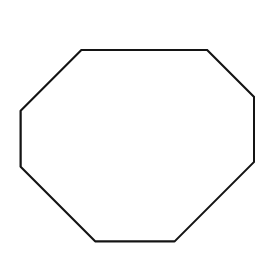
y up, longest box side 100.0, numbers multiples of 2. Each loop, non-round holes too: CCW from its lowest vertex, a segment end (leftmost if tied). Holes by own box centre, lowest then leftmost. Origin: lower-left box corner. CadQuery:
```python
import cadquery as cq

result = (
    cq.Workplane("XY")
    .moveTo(32.0, 0.0)
    .lineTo(66.0, 0.0)
    .lineTo(100.0, 34.0)
    .lineTo(100.0, 62.0)
    .lineTo(80.0, 82.0)
    .lineTo(26.0, 82.0)
    .lineTo(0.0, 56.0)
    .lineTo(0.0, 32.0)
    .close()
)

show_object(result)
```